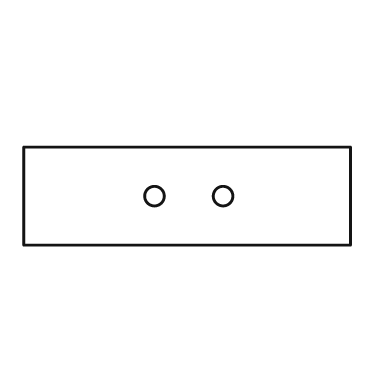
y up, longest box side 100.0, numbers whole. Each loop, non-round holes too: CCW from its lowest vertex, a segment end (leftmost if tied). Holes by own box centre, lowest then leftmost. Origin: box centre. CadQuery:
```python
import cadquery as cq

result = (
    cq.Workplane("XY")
    .moveTo(-50.0, -15.0)
    .lineTo(50.0, -15.0)
    .lineTo(50.0, 15.0)
    .lineTo(-50.0, 15.0)
    .close()
    .moveTo(-10.0, 0.0)
    .circle(3.0)
    .moveTo(11.0, 0.0)
    .circle(3.0)
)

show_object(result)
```